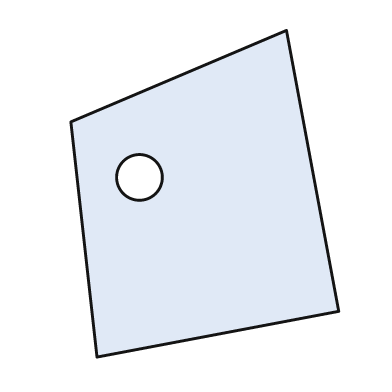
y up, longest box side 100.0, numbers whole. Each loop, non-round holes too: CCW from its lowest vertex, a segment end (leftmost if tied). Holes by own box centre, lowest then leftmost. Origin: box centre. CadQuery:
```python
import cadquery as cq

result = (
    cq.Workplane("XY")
    .moveTo(-33.0, -50.0)
    .lineTo(41.0, -36.0)
    .lineTo(25.0, 50.0)
    .lineTo(-41.0, 22.0)
    .close()
    .moveTo(-20.0, 5.0)
    .circle(7.0)
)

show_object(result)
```